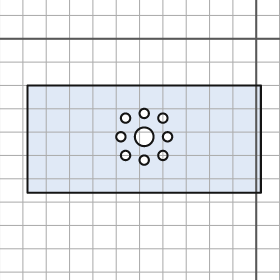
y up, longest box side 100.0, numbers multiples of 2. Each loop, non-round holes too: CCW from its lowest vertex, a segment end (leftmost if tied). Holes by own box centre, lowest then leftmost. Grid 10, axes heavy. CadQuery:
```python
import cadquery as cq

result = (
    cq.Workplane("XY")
    .moveTo(-98.0, -66.0)
    .lineTo(2.0, -66.0)
    .lineTo(2.0, -20.0)
    .lineTo(-98.0, -20.0)
    .close()
    .moveTo(-48.0, -52.0)
    .circle(2.0)
    .moveTo(-56.0, -50.0)
    .circle(2.0)
    .moveTo(-40.0, -50.0)
    .circle(2.0)
    .moveTo(-58.0, -42.0)
    .circle(2.0)
    .moveTo(-48.0, -42.0)
    .circle(4.0)
    .moveTo(-38.0, -42.0)
    .circle(2.0)
    .moveTo(-56.0, -34.0)
    .circle(2.0)
    .moveTo(-40.0, -34.0)
    .circle(2.0)
    .moveTo(-48.0, -32.0)
    .circle(2.0)
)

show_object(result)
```